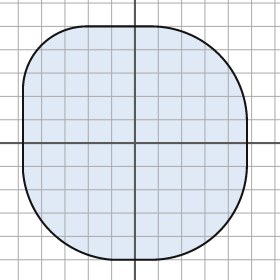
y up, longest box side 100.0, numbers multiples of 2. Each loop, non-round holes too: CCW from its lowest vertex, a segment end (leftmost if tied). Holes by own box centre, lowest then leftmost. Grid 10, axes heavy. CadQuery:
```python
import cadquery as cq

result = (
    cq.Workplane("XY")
    .moveTo(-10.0, -50.0)
    .lineTo(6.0, -50.0)
    .threePointArc((36.0, -38.0), (48.0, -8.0))
    .lineTo(48.0, 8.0)
    .threePointArc((36.0, 38.0), (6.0, 50.0))
    .lineTo(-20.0, 50.0)
    .threePointArc((-40.0, 42.0), (-48.0, 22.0))
    .lineTo(-48.0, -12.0)
    .threePointArc((-36.0, -38.0), (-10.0, -50.0))
    .close()
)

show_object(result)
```